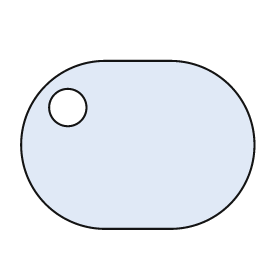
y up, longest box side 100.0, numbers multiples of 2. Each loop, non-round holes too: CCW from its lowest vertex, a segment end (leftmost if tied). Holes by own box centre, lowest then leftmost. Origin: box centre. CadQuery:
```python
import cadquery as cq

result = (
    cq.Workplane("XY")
    .moveTo(-14.0, -36.0)
    .lineTo(14.0, -36.0)
    .threePointArc((50.0, 0.0), (14.0, 36.0))
    .lineTo(-14.0, 36.0)
    .threePointArc((-50.0, 0.0), (-14.0, -36.0))
    .close()
    .moveTo(-30.0, 16.0)
    .circle(8.0)
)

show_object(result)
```